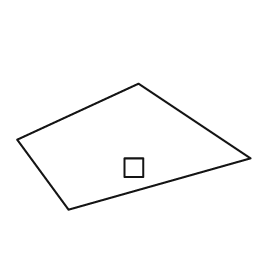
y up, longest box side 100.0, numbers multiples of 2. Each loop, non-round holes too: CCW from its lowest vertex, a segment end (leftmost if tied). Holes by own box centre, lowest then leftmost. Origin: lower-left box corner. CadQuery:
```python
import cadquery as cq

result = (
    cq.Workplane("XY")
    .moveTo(22.0, 0.0)
    .lineTo(100.0, 22.0)
    .lineTo(52.0, 54.0)
    .lineTo(0.0, 30.0)
    .close()
    .moveTo(46.0, 14.0)
    .lineTo(54.0, 14.0)
    .lineTo(54.0, 22.0)
    .lineTo(46.0, 22.0)
    .close()
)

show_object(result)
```